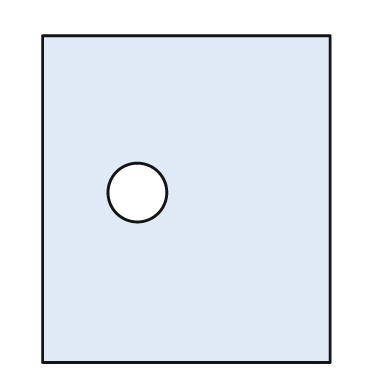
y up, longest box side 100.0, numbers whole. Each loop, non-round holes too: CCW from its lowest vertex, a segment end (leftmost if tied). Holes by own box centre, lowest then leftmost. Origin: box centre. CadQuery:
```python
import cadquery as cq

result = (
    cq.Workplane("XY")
    .moveTo(-44.0, -50.0)
    .lineTo(44.0, -50.0)
    .lineTo(44.0, 50.0)
    .lineTo(-44.0, 50.0)
    .close()
    .moveTo(-15.0, 2.0)
    .circle(9.0)
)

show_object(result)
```